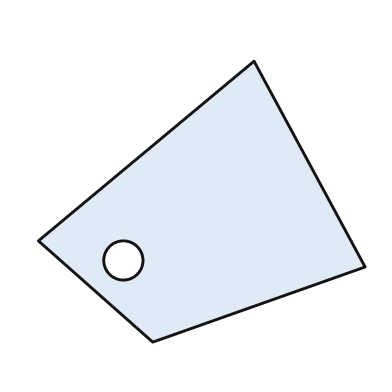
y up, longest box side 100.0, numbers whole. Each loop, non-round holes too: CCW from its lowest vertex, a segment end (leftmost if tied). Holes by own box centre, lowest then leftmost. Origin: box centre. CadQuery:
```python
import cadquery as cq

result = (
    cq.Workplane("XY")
    .moveTo(-15.0, -43.0)
    .lineTo(50.0, -20.0)
    .lineTo(16.0, 43.0)
    .lineTo(-50.0, -12.0)
    .close()
    .moveTo(-24.0, -18.0)
    .circle(6.0)
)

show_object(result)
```